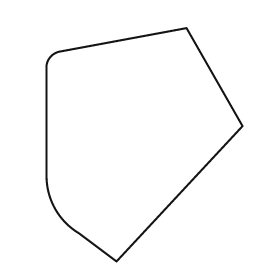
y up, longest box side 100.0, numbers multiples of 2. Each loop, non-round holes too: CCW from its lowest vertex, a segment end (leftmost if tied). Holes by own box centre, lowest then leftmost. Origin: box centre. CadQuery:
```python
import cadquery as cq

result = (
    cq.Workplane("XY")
    .moveTo(-12.0, -50.0)
    .lineTo(42.0, 8.0)
    .lineTo(18.0, 50.0)
    .lineTo(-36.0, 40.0)
    .threePointArc((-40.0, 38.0), (-42.0, 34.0))
    .lineTo(-42.0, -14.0)
    .threePointArc((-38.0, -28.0), (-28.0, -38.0))
    .close()
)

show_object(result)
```